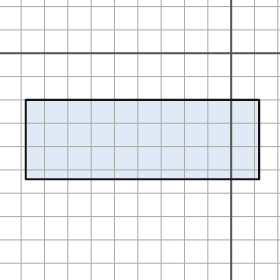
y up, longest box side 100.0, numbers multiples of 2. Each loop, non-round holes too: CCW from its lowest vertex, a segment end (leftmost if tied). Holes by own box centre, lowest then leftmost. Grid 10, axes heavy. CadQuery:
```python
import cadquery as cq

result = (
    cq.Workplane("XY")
    .moveTo(-88.0, -54.0)
    .lineTo(12.0, -54.0)
    .lineTo(12.0, -20.0)
    .lineTo(-88.0, -20.0)
    .close()
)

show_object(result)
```